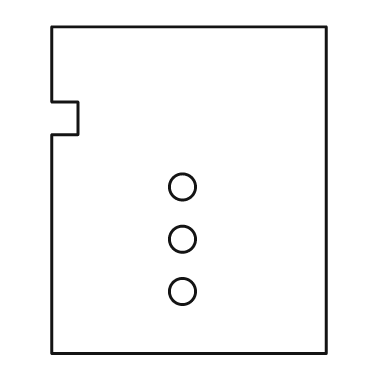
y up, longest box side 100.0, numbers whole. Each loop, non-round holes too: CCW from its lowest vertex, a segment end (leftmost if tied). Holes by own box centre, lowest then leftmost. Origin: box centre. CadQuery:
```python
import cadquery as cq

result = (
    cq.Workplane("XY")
    .moveTo(-42.0, -50.0)
    .lineTo(42.0, -50.0)
    .lineTo(42.0, 50.0)
    .lineTo(-42.0, 50.0)
    .lineTo(-42.0, 27.0)
    .lineTo(-34.0, 27.0)
    .lineTo(-34.0, 17.0)
    .lineTo(-42.0, 17.0)
    .close()
    .moveTo(-2.0, -31.0)
    .circle(4.0)
    .moveTo(-2.0, -15.0)
    .circle(4.0)
    .moveTo(-2.0, 1.0)
    .circle(4.0)
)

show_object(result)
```